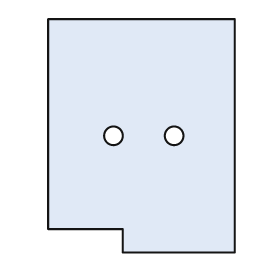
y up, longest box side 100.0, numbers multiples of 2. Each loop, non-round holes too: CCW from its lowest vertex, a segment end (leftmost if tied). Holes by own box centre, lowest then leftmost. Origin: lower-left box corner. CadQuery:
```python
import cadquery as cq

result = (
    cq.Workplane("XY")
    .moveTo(32.0, 0.0)
    .lineTo(80.0, 0.0)
    .lineTo(80.0, 100.0)
    .lineTo(0.0, 100.0)
    .lineTo(0.0, 10.0)
    .lineTo(32.0, 10.0)
    .close()
    .moveTo(28.0, 50.0)
    .circle(4.0)
    .moveTo(54.0, 50.0)
    .circle(4.0)
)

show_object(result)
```